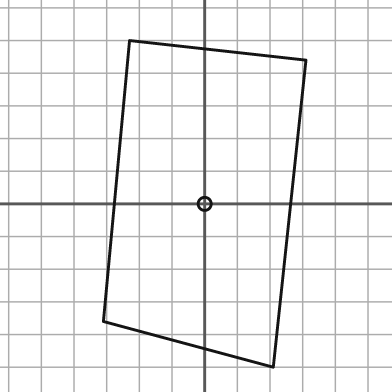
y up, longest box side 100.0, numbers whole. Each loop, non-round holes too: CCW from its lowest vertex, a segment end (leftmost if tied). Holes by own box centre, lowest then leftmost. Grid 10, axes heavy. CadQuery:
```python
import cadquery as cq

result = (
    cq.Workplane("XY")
    .moveTo(21.0, -50.0)
    .lineTo(31.0, 44.0)
    .lineTo(-23.0, 50.0)
    .lineTo(-31.0, -36.0)
    .close()
    .moveTo(0.0, 0.0)
    .circle(2.0)
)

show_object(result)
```